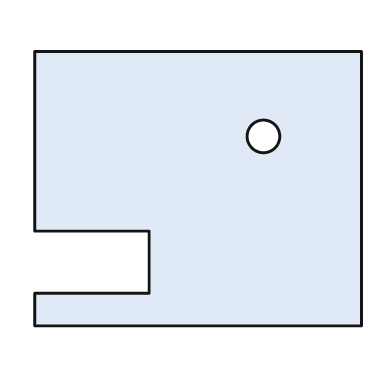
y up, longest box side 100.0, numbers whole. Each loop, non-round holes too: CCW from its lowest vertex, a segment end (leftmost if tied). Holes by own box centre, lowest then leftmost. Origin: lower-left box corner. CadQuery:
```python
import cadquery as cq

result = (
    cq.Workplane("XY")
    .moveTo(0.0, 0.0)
    .lineTo(100.0, 0.0)
    .lineTo(100.0, 84.0)
    .lineTo(0.0, 84.0)
    .lineTo(0.0, 29.0)
    .lineTo(35.0, 29.0)
    .lineTo(35.0, 10.0)
    .lineTo(0.0, 10.0)
    .close()
    .moveTo(70.0, 58.0)
    .circle(5.0)
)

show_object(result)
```